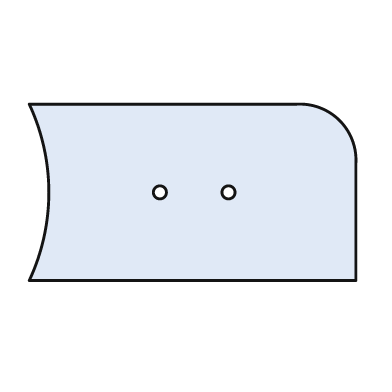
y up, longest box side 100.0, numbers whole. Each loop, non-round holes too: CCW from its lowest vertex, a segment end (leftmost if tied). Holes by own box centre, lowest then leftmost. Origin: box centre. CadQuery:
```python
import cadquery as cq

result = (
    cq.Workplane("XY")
    .moveTo(-50.0, -27.0)
    .lineTo(50.0, -27.0)
    .lineTo(50.0, 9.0)
    .threePointArc((45.0, 22.0), (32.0, 27.0))
    .lineTo(-50.0, 27.0)
    .threePointArc((-44.0, 0.0), (-50.0, -27.0))
    .close()
    .moveTo(-10.0, 0.0)
    .circle(2.0)
    .moveTo(11.0, 0.0)
    .circle(2.0)
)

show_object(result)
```